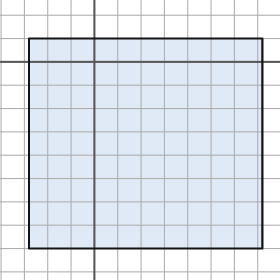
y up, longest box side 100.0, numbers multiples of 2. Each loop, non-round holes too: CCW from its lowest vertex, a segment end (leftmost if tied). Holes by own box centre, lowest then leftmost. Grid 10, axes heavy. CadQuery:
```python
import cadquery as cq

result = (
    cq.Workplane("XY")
    .moveTo(-28.0, -80.0)
    .lineTo(72.0, -80.0)
    .lineTo(72.0, 10.0)
    .lineTo(-28.0, 10.0)
    .close()
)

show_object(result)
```